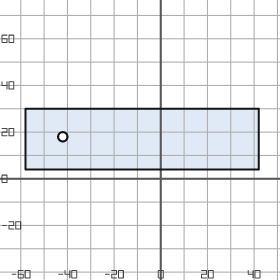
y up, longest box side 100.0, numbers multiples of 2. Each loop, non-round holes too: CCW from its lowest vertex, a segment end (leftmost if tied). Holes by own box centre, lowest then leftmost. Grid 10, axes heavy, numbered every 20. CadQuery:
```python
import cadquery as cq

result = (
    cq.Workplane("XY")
    .moveTo(-58.0, 4.0)
    .lineTo(42.0, 4.0)
    .lineTo(42.0, 30.0)
    .lineTo(-58.0, 30.0)
    .close()
    .moveTo(-42.0, 18.0)
    .circle(2.0)
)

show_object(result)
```